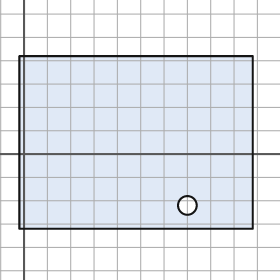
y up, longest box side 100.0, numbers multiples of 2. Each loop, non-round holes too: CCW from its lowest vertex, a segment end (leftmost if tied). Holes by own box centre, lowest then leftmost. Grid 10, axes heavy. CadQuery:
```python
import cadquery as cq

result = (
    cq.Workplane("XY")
    .moveTo(-2.0, -32.0)
    .lineTo(98.0, -32.0)
    .lineTo(98.0, 42.0)
    .lineTo(-2.0, 42.0)
    .close()
    .moveTo(70.0, -22.0)
    .circle(4.0)
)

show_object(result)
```